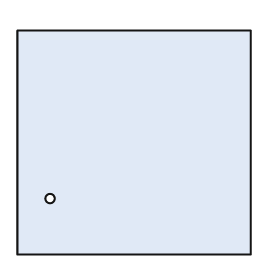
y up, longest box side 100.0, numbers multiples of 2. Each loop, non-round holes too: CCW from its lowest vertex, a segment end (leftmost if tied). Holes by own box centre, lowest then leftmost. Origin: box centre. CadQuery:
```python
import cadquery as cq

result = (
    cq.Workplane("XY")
    .moveTo(-50.0, -48.0)
    .lineTo(50.0, -48.0)
    .lineTo(50.0, 48.0)
    .lineTo(-50.0, 48.0)
    .close()
    .moveTo(-36.0, -24.0)
    .circle(2.0)
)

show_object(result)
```